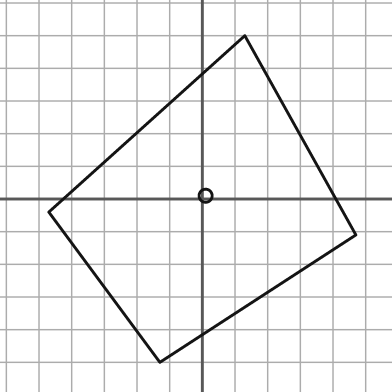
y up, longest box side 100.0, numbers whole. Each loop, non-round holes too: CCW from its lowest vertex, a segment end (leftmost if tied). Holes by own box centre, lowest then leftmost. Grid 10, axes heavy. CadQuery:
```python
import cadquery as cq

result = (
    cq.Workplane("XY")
    .moveTo(-13.0, -50.0)
    .lineTo(47.0, -11.0)
    .lineTo(13.0, 50.0)
    .lineTo(-47.0, -4.0)
    .close()
    .moveTo(1.0, 1.0)
    .circle(2.0)
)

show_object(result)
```